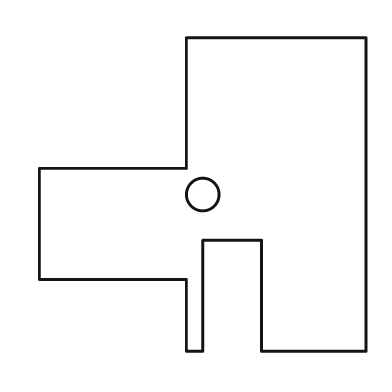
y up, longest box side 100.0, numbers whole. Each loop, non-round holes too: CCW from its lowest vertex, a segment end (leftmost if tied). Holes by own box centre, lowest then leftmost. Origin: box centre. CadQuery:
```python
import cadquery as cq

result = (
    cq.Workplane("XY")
    .moveTo(-5.0, -48.0)
    .lineTo(0.0, -48.0)
    .lineTo(0.0, -14.0)
    .lineTo(18.0, -14.0)
    .lineTo(18.0, -48.0)
    .lineTo(50.0, -48.0)
    .lineTo(50.0, 48.0)
    .lineTo(-5.0, 48.0)
    .lineTo(-5.0, 8.0)
    .lineTo(-50.0, 8.0)
    .lineTo(-50.0, -26.0)
    .lineTo(-5.0, -26.0)
    .close()
    .moveTo(0.0, 0.0)
    .circle(5.0)
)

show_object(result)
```